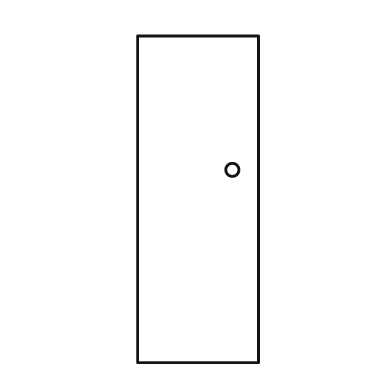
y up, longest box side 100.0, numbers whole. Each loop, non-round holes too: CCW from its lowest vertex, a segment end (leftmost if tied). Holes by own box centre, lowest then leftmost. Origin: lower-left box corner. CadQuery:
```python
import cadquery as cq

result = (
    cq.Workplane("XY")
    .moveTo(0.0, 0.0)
    .lineTo(37.0, 0.0)
    .lineTo(37.0, 100.0)
    .lineTo(0.0, 100.0)
    .close()
    .moveTo(29.0, 59.0)
    .circle(2.0)
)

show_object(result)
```